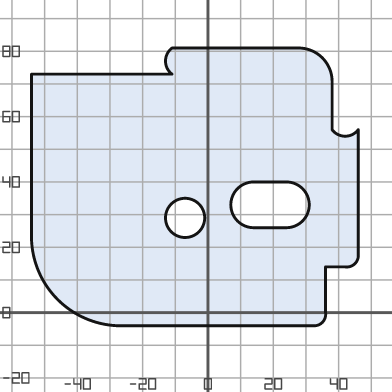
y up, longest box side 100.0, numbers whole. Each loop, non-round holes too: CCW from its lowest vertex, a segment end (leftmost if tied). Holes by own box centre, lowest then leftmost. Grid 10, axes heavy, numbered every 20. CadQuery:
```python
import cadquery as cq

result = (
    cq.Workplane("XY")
    .moveTo(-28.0, -4.0)
    .lineTo(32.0, -4.0)
    .threePointArc((35.0, -3.0), (36.0, 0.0))
    .lineTo(36.0, 14.0)
    .lineTo(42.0, 14.0)
    .threePointArc((45.0, 15.0), (46.0, 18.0))
    .lineTo(46.0, 56.0)
    .threePointArc((42.0, 54.0), (38.0, 56.0))
    .lineTo(38.0, 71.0)
    .threePointArc((35.0, 78.0), (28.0, 81.0))
    .lineTo(-11.0, 81.0)
    .threePointArc((-13.0, 77.0), (-11.0, 73.0))
    .lineTo(-54.0, 73.0)
    .lineTo(-54.0, 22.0)
    .threePointArc((-46.0, 4.0), (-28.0, -4.0))
    .close()
    .moveTo(-7.0, 29.0)
    .circle(6.0)
    .moveTo(14.0, 26.0)
    .lineTo(24.0, 26.0)
    .threePointArc((31.0, 33.0), (24.0, 40.0))
    .lineTo(14.0, 40.0)
    .threePointArc((7.0, 33.0), (14.0, 26.0))
    .close()
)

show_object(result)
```